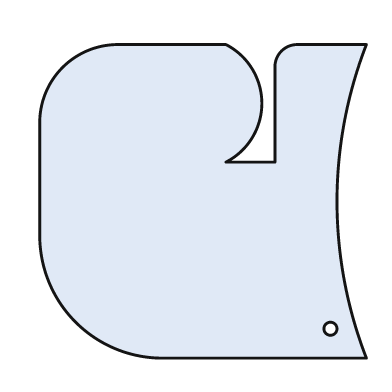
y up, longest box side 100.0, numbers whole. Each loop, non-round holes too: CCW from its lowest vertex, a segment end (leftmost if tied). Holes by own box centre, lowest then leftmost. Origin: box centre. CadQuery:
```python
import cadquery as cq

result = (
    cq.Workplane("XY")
    .moveTo(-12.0, -48.0)
    .lineTo(50.0, -48.0)
    .threePointArc((41.0, 0.0), (50.0, 48.0))
    .lineTo(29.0, 48.0)
    .threePointArc((24.0, 46.0), (22.0, 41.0))
    .lineTo(22.0, 12.0)
    .lineTo(7.0, 12.0)
    .threePointArc((18.0, 30.0), (7.0, 48.0))
    .lineTo(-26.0, 48.0)
    .threePointArc((-43.0, 41.0), (-50.0, 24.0))
    .lineTo(-50.0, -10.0)
    .threePointArc((-39.0, -37.0), (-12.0, -48.0))
    .close()
    .moveTo(39.0, -39.0)
    .circle(2.0)
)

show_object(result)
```